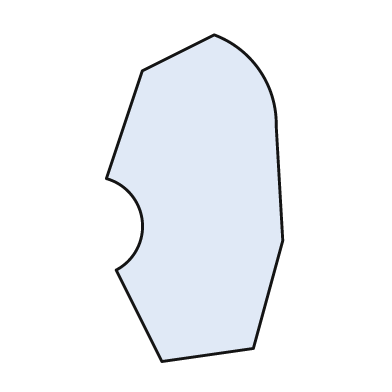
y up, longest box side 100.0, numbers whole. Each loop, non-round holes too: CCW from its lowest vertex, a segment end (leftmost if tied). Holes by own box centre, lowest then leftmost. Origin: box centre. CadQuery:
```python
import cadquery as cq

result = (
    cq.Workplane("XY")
    .moveTo(-10.0, -50.0)
    .lineTo(18.0, -46.0)
    .lineTo(27.0, -13.0)
    .lineTo(25.0, 22.0)
    .threePointArc((20.0, 39.0), (6.0, 50.0))
    .lineTo(-16.0, 39.0)
    .lineTo(-27.0, 6.0)
    .threePointArc((-16.0, -7.0), (-24.0, -22.0))
    .close()
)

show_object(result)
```